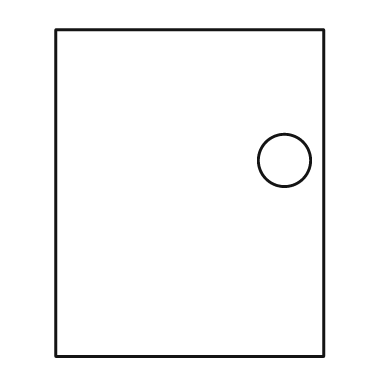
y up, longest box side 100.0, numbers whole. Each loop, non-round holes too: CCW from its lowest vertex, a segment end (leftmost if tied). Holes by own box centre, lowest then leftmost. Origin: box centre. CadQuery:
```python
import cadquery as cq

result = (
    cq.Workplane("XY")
    .moveTo(-41.0, -50.0)
    .lineTo(41.0, -50.0)
    .lineTo(41.0, 50.0)
    .lineTo(-41.0, 50.0)
    .close()
    .moveTo(29.0, 10.0)
    .circle(8.0)
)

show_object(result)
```